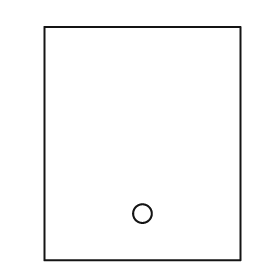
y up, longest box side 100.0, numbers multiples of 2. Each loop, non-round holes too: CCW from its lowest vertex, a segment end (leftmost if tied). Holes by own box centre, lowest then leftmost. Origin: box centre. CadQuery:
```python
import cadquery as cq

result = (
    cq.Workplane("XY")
    .moveTo(-42.0, -50.0)
    .lineTo(42.0, -50.0)
    .lineTo(42.0, 50.0)
    .lineTo(-42.0, 50.0)
    .close()
    .moveTo(0.0, -30.0)
    .circle(4.0)
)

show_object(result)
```